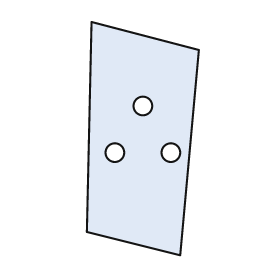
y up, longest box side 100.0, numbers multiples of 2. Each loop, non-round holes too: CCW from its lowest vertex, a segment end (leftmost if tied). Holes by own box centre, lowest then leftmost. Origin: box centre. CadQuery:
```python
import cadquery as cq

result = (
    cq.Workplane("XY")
    .moveTo(16.0, -50.0)
    .lineTo(24.0, 38.0)
    .lineTo(-22.0, 50.0)
    .lineTo(-24.0, -40.0)
    .close()
    .moveTo(-12.0, -6.0)
    .circle(4.0)
    .moveTo(12.0, -6.0)
    .circle(4.0)
    .moveTo(0.0, 14.0)
    .circle(4.0)
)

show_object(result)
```